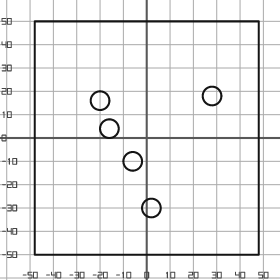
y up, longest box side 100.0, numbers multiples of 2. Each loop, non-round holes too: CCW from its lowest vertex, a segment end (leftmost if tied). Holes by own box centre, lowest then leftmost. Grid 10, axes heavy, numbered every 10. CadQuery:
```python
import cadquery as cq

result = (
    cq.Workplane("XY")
    .moveTo(-48.0, -50.0)
    .lineTo(48.0, -50.0)
    .lineTo(48.0, 50.0)
    .lineTo(-48.0, 50.0)
    .close()
    .moveTo(2.0, -30.0)
    .circle(4.0)
    .moveTo(-6.0, -10.0)
    .circle(4.0)
    .moveTo(-16.0, 4.0)
    .circle(4.0)
    .moveTo(-20.0, 16.0)
    .circle(4.0)
    .moveTo(28.0, 18.0)
    .circle(4.0)
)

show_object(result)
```